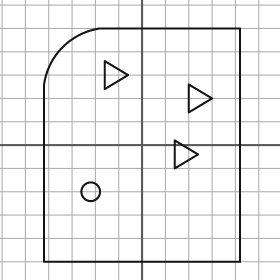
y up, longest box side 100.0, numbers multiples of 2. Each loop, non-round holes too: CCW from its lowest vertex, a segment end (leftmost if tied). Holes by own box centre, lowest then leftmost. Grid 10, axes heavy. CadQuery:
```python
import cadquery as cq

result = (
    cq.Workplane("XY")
    .moveTo(-42.0, -50.0)
    .lineTo(42.0, -50.0)
    .lineTo(42.0, 50.0)
    .lineTo(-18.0, 50.0)
    .threePointArc((-34.0, 42.0), (-42.0, 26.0))
    .close()
    .moveTo(-22.0, -20.0)
    .circle(4.0)
    .moveTo(14.0, -10.0)
    .lineTo(24.0, -4.0)
    .lineTo(14.0, 2.0)
    .close()
    .moveTo(20.0, 14.0)
    .lineTo(30.0, 20.0)
    .lineTo(20.0, 26.0)
    .close()
    .moveTo(-16.0, 24.0)
    .lineTo(-6.0, 30.0)
    .lineTo(-16.0, 36.0)
    .close()
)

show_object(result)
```